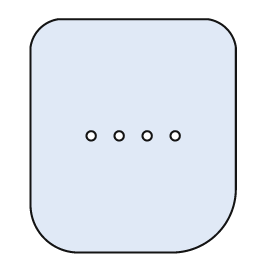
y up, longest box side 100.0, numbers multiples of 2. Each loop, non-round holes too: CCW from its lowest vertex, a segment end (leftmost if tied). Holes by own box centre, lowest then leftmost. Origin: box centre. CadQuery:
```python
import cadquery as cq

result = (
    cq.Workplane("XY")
    .moveTo(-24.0, -50.0)
    .lineTo(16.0, -50.0)
    .threePointArc((36.0, -42.0), (44.0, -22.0))
    .lineTo(44.0, 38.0)
    .threePointArc((40.0, 46.0), (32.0, 50.0))
    .lineTo(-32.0, 50.0)
    .threePointArc((-40.0, 46.0), (-44.0, 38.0))
    .lineTo(-44.0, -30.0)
    .threePointArc((-38.0, -44.0), (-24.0, -50.0))
    .close()
    .moveTo(-18.0, 0.0)
    .circle(2.0)
    .moveTo(-6.0, 0.0)
    .circle(2.0)
    .moveTo(6.0, 0.0)
    .circle(2.0)
    .moveTo(18.0, 0.0)
    .circle(2.0)
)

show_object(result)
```